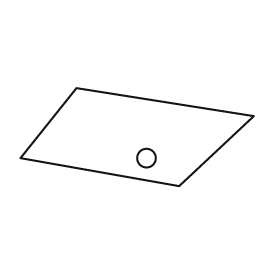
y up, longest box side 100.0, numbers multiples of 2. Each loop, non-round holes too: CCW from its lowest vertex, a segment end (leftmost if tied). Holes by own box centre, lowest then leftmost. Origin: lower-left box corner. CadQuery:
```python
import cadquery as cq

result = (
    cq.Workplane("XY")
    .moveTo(68.0, 0.0)
    .lineTo(100.0, 30.0)
    .lineTo(24.0, 42.0)
    .lineTo(0.0, 12.0)
    .close()
    .moveTo(54.0, 12.0)
    .circle(4.0)
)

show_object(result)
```